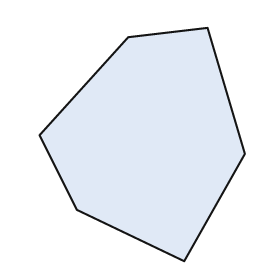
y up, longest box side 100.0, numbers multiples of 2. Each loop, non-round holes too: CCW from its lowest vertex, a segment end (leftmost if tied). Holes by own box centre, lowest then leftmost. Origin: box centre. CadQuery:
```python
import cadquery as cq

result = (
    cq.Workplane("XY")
    .moveTo(18.0, -50.0)
    .lineTo(44.0, -4.0)
    .lineTo(28.0, 50.0)
    .lineTo(-6.0, 46.0)
    .lineTo(-44.0, 4.0)
    .lineTo(-28.0, -28.0)
    .close()
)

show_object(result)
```